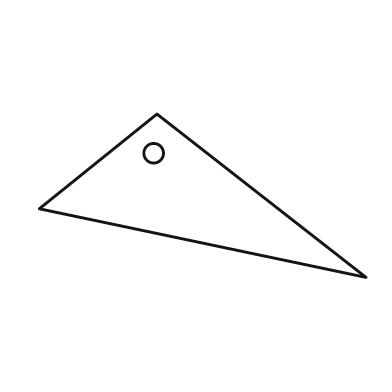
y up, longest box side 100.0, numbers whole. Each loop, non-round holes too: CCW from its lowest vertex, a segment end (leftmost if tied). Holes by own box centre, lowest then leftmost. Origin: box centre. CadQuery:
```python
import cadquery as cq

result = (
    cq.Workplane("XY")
    .moveTo(50.0, -25.0)
    .lineTo(-14.0, 25.0)
    .lineTo(-50.0, -4.0)
    .close()
    .moveTo(-15.0, 13.0)
    .circle(3.0)
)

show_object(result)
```